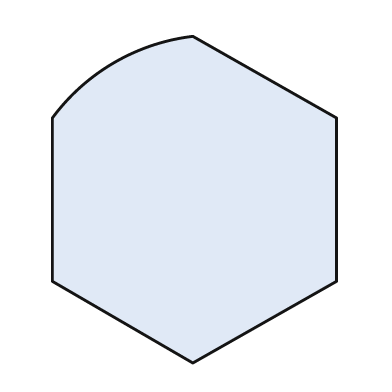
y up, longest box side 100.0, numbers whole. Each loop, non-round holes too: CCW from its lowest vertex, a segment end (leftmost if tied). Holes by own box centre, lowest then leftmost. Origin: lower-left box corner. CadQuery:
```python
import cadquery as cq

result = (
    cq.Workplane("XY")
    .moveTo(43.0, 0.0)
    .lineTo(87.0, 25.0)
    .lineTo(87.0, 75.0)
    .lineTo(43.0, 100.0)
    .threePointArc((19.0, 92.0), (0.0, 75.0))
    .lineTo(0.0, 25.0)
    .close()
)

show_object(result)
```